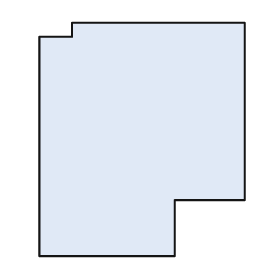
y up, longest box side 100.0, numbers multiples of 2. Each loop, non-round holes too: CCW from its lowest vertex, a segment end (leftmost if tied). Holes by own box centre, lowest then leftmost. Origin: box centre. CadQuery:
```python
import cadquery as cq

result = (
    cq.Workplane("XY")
    .moveTo(-44.0, -50.0)
    .lineTo(14.0, -50.0)
    .lineTo(14.0, -26.0)
    .lineTo(44.0, -26.0)
    .lineTo(44.0, 50.0)
    .lineTo(-30.0, 50.0)
    .lineTo(-30.0, 44.0)
    .lineTo(-44.0, 44.0)
    .close()
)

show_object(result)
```